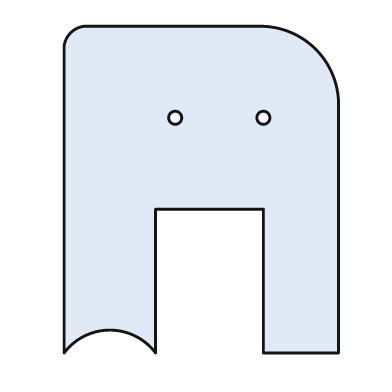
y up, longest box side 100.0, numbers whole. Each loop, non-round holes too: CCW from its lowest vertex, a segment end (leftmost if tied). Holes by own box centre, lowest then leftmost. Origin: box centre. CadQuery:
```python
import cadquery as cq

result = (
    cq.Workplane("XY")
    .moveTo(-42.0, -50.0)
    .threePointArc((-28.0, -43.0), (-14.0, -50.0))
    .lineTo(-14.0, -6.0)
    .lineTo(19.0, -6.0)
    .lineTo(19.0, -50.0)
    .lineTo(42.0, -50.0)
    .lineTo(42.0, 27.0)
    .threePointArc((35.0, 43.0), (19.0, 50.0))
    .lineTo(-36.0, 50.0)
    .threePointArc((-40.0, 48.0), (-42.0, 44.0))
    .close()
    .moveTo(-8.0, 22.0)
    .circle(2.0)
    .moveTo(19.0, 22.0)
    .circle(2.0)
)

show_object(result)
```